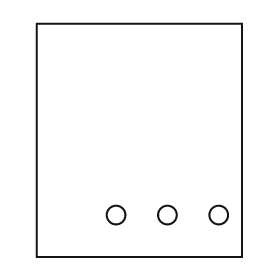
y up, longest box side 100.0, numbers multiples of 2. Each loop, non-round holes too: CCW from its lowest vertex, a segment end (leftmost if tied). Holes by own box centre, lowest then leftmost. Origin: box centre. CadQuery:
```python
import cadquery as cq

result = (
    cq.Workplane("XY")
    .moveTo(-44.0, -50.0)
    .lineTo(44.0, -50.0)
    .lineTo(44.0, 50.0)
    .lineTo(-44.0, 50.0)
    .close()
    .moveTo(-10.0, -32.0)
    .circle(4.0)
    .moveTo(12.0, -32.0)
    .circle(4.0)
    .moveTo(34.0, -32.0)
    .circle(4.0)
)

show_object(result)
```